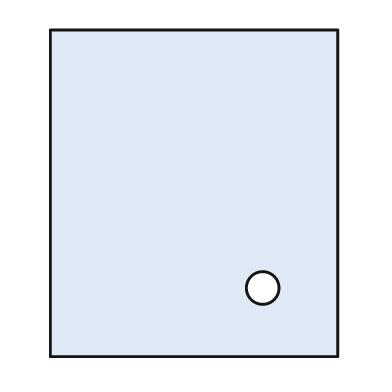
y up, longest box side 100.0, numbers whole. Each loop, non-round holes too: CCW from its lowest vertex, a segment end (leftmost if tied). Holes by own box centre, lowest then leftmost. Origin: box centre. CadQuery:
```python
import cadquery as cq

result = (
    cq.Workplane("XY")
    .moveTo(-44.0, -50.0)
    .lineTo(44.0, -50.0)
    .lineTo(44.0, 50.0)
    .lineTo(-44.0, 50.0)
    .close()
    .moveTo(21.0, -29.0)
    .circle(5.0)
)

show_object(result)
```